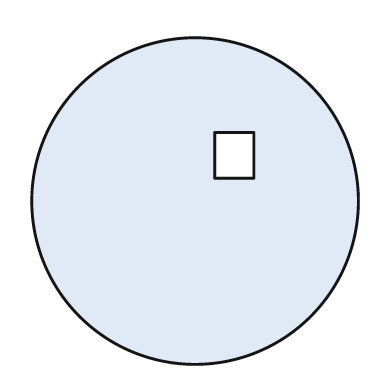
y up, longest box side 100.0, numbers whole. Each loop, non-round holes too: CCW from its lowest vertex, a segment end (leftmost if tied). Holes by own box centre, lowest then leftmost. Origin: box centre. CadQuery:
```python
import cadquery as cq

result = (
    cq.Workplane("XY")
    .moveTo(0.0, 0.0)
    .circle(50.0)
    .moveTo(6.0, 7.0)
    .lineTo(18.0, 7.0)
    .lineTo(18.0, 21.0)
    .lineTo(6.0, 21.0)
    .close()
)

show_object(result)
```